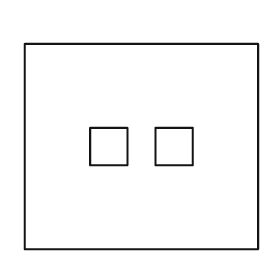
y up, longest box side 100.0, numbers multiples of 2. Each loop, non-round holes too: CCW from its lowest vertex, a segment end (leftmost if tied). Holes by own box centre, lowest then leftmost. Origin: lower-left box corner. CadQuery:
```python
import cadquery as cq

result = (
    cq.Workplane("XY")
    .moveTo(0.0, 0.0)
    .lineTo(100.0, 0.0)
    .lineTo(100.0, 88.0)
    .lineTo(0.0, 88.0)
    .close()
    .moveTo(28.0, 36.0)
    .lineTo(44.0, 36.0)
    .lineTo(44.0, 52.0)
    .lineTo(28.0, 52.0)
    .close()
    .moveTo(56.0, 36.0)
    .lineTo(72.0, 36.0)
    .lineTo(72.0, 52.0)
    .lineTo(56.0, 52.0)
    .close()
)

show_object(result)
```